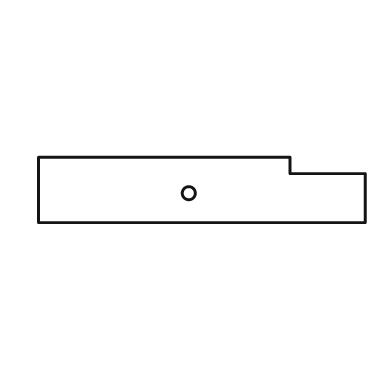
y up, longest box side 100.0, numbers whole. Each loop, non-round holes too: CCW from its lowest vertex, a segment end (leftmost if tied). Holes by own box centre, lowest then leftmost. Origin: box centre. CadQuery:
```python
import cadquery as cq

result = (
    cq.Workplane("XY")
    .moveTo(-50.0, -10.0)
    .lineTo(50.0, -10.0)
    .lineTo(50.0, 5.0)
    .lineTo(27.0, 5.0)
    .lineTo(27.0, 10.0)
    .lineTo(-50.0, 10.0)
    .close()
    .moveTo(-4.0, -1.0)
    .circle(2.0)
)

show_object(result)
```